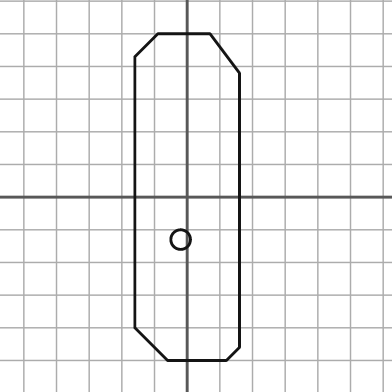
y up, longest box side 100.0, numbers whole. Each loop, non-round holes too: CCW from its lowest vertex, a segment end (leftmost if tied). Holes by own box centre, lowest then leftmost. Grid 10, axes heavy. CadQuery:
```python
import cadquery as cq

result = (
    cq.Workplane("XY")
    .moveTo(-6.0, -50.0)
    .lineTo(12.0, -50.0)
    .lineTo(16.0, -46.0)
    .lineTo(16.0, 38.0)
    .lineTo(7.0, 50.0)
    .lineTo(-9.0, 50.0)
    .lineTo(-16.0, 43.0)
    .lineTo(-16.0, -40.0)
    .close()
    .moveTo(-2.0, -13.0)
    .circle(3.0)
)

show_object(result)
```